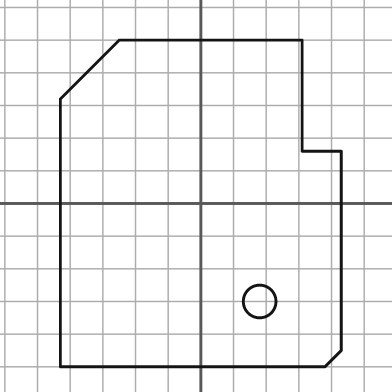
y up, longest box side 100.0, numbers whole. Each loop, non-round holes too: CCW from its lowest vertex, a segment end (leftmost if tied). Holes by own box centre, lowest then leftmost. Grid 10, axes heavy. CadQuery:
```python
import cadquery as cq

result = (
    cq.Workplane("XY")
    .moveTo(-43.0, -50.0)
    .lineTo(38.0, -50.0)
    .lineTo(43.0, -45.0)
    .lineTo(43.0, 16.0)
    .lineTo(31.0, 16.0)
    .lineTo(31.0, 50.0)
    .lineTo(-25.0, 50.0)
    .lineTo(-43.0, 32.0)
    .close()
    .moveTo(18.0, -30.0)
    .circle(5.0)
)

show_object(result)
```